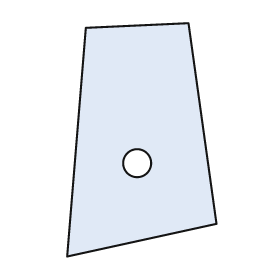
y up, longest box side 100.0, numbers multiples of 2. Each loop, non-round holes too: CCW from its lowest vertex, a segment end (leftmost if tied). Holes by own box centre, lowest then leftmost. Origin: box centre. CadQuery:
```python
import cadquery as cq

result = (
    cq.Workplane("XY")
    .moveTo(-32.0, -50.0)
    .lineTo(32.0, -36.0)
    .lineTo(20.0, 50.0)
    .lineTo(-24.0, 48.0)
    .close()
    .moveTo(-2.0, -10.0)
    .circle(6.0)
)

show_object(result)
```